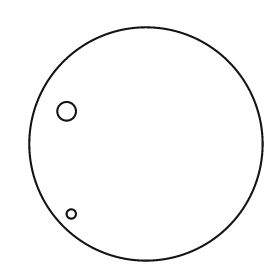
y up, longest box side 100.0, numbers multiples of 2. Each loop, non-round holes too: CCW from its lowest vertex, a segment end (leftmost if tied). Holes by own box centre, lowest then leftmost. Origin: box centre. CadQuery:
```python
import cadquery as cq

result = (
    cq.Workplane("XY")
    .moveTo(0.0, 0.0)
    .circle(50.0)
    .moveTo(-32.0, -30.0)
    .circle(2.0)
    .moveTo(-34.0, 14.0)
    .circle(4.0)
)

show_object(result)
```